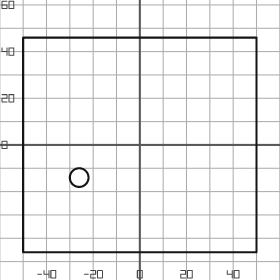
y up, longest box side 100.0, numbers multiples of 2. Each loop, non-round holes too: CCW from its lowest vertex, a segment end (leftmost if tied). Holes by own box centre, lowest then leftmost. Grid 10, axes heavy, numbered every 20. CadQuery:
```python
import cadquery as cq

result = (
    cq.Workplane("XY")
    .moveTo(-50.0, -46.0)
    .lineTo(50.0, -46.0)
    .lineTo(50.0, 46.0)
    .lineTo(-50.0, 46.0)
    .close()
    .moveTo(-26.0, -14.0)
    .circle(4.0)
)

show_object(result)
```